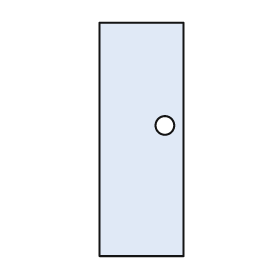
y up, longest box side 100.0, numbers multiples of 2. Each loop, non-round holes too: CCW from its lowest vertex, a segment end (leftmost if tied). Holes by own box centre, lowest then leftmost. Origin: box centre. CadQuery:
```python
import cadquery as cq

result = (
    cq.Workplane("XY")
    .moveTo(-18.0, -50.0)
    .lineTo(18.0, -50.0)
    .lineTo(18.0, 50.0)
    .lineTo(-18.0, 50.0)
    .close()
    .moveTo(10.0, 6.0)
    .circle(4.0)
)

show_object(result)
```